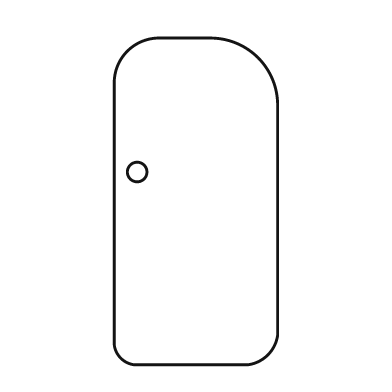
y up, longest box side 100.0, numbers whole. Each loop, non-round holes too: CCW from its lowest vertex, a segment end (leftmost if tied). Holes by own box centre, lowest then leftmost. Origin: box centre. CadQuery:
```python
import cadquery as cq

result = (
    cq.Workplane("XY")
    .moveTo(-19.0, -50.0)
    .lineTo(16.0, -50.0)
    .threePointArc((22.0, -47.0), (25.0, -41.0))
    .lineTo(25.0, 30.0)
    .threePointArc((19.0, 44.0), (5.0, 50.0))
    .lineTo(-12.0, 50.0)
    .threePointArc((-21.0, 46.0), (-25.0, 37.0))
    .lineTo(-25.0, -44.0)
    .threePointArc((-23.0, -48.0), (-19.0, -50.0))
    .close()
    .moveTo(-18.0, 9.0)
    .circle(3.0)
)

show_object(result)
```